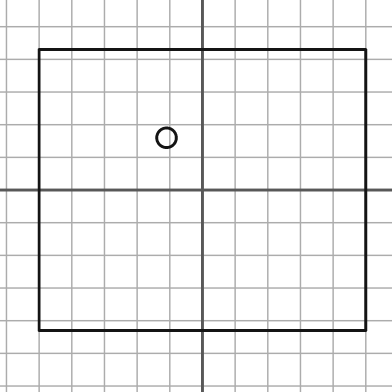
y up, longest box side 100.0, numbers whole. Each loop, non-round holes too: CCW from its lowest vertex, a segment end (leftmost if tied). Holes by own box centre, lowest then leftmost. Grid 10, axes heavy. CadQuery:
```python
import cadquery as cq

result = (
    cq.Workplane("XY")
    .moveTo(-50.0, -43.0)
    .lineTo(50.0, -43.0)
    .lineTo(50.0, 43.0)
    .lineTo(-50.0, 43.0)
    .close()
    .moveTo(-11.0, 16.0)
    .circle(3.0)
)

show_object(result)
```